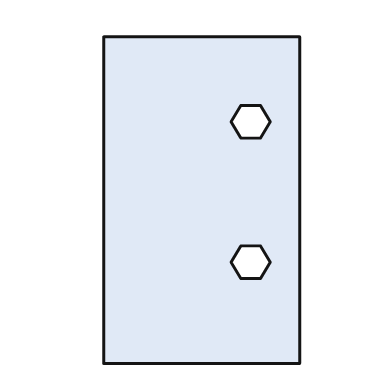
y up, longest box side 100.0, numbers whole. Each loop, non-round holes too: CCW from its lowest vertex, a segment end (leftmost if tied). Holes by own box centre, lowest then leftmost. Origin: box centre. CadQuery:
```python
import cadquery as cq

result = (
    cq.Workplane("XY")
    .moveTo(-30.0, -50.0)
    .lineTo(30.0, -50.0)
    .lineTo(30.0, 50.0)
    .lineTo(-30.0, 50.0)
    .close()
    .moveTo(12.0, -24.0)
    .lineTo(18.0, -24.0)
    .lineTo(21.0, -19.0)
    .lineTo(18.0, -14.0)
    .lineTo(12.0, -14.0)
    .lineTo(9.0, -19.0)
    .close()
    .moveTo(12.0, 19.0)
    .lineTo(18.0, 19.0)
    .lineTo(21.0, 24.0)
    .lineTo(18.0, 29.0)
    .lineTo(12.0, 29.0)
    .lineTo(9.0, 24.0)
    .close()
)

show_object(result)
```